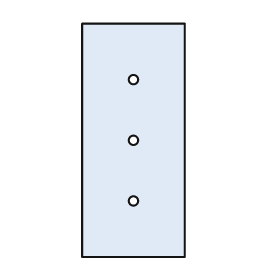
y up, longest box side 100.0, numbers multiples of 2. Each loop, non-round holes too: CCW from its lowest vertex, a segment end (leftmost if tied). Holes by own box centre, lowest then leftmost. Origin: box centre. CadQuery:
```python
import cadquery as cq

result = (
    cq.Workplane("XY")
    .moveTo(-22.0, -50.0)
    .lineTo(22.0, -50.0)
    .lineTo(22.0, 50.0)
    .lineTo(-22.0, 50.0)
    .close()
    .moveTo(0.0, -26.0)
    .circle(2.0)
    .moveTo(0.0, 0.0)
    .circle(2.0)
    .moveTo(0.0, 26.0)
    .circle(2.0)
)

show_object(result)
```